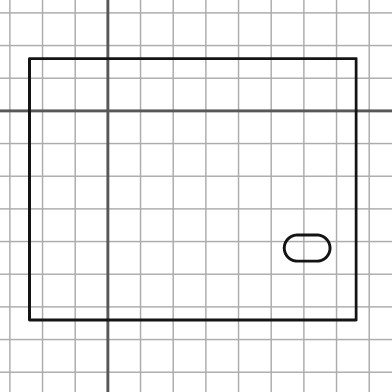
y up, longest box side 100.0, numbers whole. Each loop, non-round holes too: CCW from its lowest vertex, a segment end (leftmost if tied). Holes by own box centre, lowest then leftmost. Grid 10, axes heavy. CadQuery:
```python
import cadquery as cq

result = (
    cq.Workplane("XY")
    .moveTo(-24.0, -64.0)
    .lineTo(76.0, -64.0)
    .lineTo(76.0, 16.0)
    .lineTo(-24.0, 16.0)
    .close()
    .moveTo(58.0, -46.0)
    .lineTo(64.0, -46.0)
    .threePointArc((68.0, -42.0), (64.0, -38.0))
    .lineTo(58.0, -38.0)
    .threePointArc((54.0, -42.0), (58.0, -46.0))
    .close()
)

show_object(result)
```